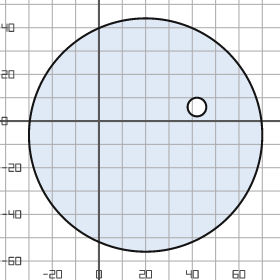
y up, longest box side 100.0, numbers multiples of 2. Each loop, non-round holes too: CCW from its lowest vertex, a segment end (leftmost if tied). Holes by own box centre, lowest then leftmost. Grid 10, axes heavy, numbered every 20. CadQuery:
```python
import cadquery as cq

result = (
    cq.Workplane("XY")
    .moveTo(20.0, -6.0)
    .circle(50.0)
    .moveTo(42.0, 6.0)
    .circle(4.0)
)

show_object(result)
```